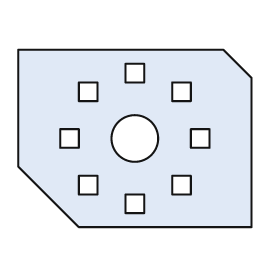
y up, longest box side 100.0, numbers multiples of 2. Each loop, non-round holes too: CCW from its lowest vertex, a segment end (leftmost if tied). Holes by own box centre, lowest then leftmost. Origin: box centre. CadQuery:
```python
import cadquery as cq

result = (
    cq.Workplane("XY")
    .moveTo(-24.0, -38.0)
    .lineTo(50.0, -38.0)
    .lineTo(50.0, 26.0)
    .lineTo(38.0, 38.0)
    .lineTo(-50.0, 38.0)
    .lineTo(-50.0, -12.0)
    .close()
    .moveTo(-4.0, -32.0)
    .lineTo(4.0, -32.0)
    .lineTo(4.0, -24.0)
    .lineTo(-4.0, -24.0)
    .close()
    .moveTo(-24.0, -24.0)
    .lineTo(-16.0, -24.0)
    .lineTo(-16.0, -16.0)
    .lineTo(-24.0, -16.0)
    .close()
    .moveTo(16.0, -24.0)
    .lineTo(24.0, -24.0)
    .lineTo(24.0, -16.0)
    .lineTo(16.0, -16.0)
    .close()
    .moveTo(-32.0, -4.0)
    .lineTo(-24.0, -4.0)
    .lineTo(-24.0, 4.0)
    .lineTo(-32.0, 4.0)
    .close()
    .moveTo(0.0, 0.0)
    .circle(10.0)
    .moveTo(24.0, -4.0)
    .lineTo(32.0, -4.0)
    .lineTo(32.0, 4.0)
    .lineTo(24.0, 4.0)
    .close()
    .moveTo(-24.0, 16.0)
    .lineTo(-16.0, 16.0)
    .lineTo(-16.0, 24.0)
    .lineTo(-24.0, 24.0)
    .close()
    .moveTo(16.0, 16.0)
    .lineTo(24.0, 16.0)
    .lineTo(24.0, 24.0)
    .lineTo(16.0, 24.0)
    .close()
    .moveTo(-4.0, 24.0)
    .lineTo(4.0, 24.0)
    .lineTo(4.0, 32.0)
    .lineTo(-4.0, 32.0)
    .close()
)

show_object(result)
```